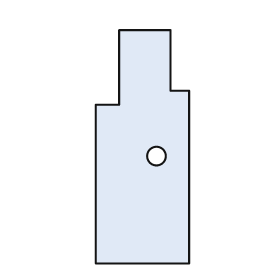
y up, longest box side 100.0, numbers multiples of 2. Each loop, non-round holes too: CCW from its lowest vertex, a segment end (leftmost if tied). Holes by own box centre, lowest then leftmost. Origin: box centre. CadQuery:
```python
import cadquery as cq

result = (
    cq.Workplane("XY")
    .moveTo(-20.0, -50.0)
    .lineTo(20.0, -50.0)
    .lineTo(20.0, 24.0)
    .lineTo(12.0, 24.0)
    .lineTo(12.0, 50.0)
    .lineTo(-10.0, 50.0)
    .lineTo(-10.0, 18.0)
    .lineTo(-20.0, 18.0)
    .close()
    .moveTo(6.0, -4.0)
    .circle(4.0)
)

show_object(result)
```